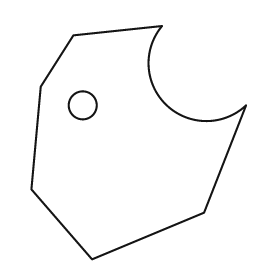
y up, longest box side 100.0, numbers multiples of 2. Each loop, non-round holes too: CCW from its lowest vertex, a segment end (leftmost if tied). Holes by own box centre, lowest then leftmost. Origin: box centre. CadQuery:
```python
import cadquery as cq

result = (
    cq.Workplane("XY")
    .moveTo(-20.0, -50.0)
    .lineTo(28.0, -30.0)
    .lineTo(46.0, 16.0)
    .threePointArc((12.0, 16.0), (10.0, 50.0))
    .lineTo(-28.0, 46.0)
    .lineTo(-42.0, 24.0)
    .lineTo(-46.0, -20.0)
    .close()
    .moveTo(-24.0, 16.0)
    .circle(6.0)
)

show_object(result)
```